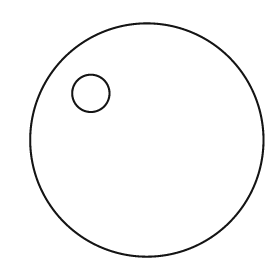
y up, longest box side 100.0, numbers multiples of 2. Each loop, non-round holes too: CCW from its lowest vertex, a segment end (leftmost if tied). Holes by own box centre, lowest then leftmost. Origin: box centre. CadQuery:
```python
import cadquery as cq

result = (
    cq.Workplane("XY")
    .moveTo(0.0, 0.0)
    .circle(50.0)
    .moveTo(-24.0, 20.0)
    .circle(8.0)
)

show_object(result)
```